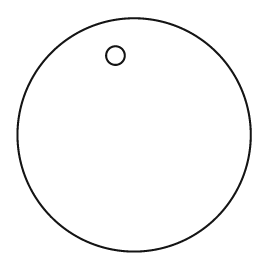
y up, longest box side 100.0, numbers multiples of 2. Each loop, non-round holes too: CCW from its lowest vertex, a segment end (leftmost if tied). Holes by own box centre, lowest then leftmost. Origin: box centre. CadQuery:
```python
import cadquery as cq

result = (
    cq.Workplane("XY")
    .moveTo(0.0, 0.0)
    .circle(50.0)
    .moveTo(-8.0, 34.0)
    .circle(4.0)
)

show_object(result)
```